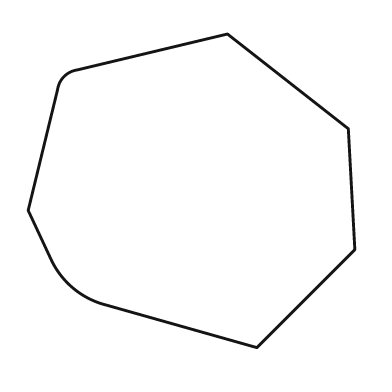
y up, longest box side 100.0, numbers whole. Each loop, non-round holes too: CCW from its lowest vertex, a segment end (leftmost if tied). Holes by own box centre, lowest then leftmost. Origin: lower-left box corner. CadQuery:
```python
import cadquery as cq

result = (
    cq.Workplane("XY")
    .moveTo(70.0, 0.0)
    .lineTo(100.0, 30.0)
    .lineTo(98.0, 67.0)
    .lineTo(61.0, 96.0)
    .lineTo(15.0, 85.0)
    .threePointArc((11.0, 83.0), (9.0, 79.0))
    .lineTo(0.0, 42.0)
    .lineTo(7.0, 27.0)
    .threePointArc((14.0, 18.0), (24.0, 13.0))
    .close()
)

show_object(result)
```